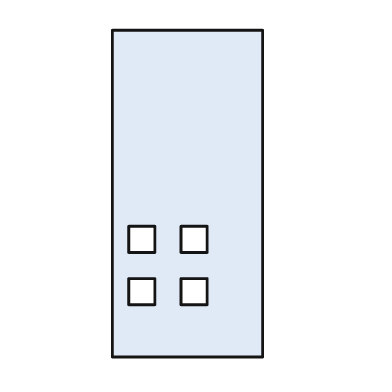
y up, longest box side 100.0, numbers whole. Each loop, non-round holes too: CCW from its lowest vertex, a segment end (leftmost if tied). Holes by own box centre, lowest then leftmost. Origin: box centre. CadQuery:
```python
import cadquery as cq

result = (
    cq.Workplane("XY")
    .moveTo(-23.0, -50.0)
    .lineTo(23.0, -50.0)
    .lineTo(23.0, 50.0)
    .lineTo(-23.0, 50.0)
    .close()
    .moveTo(-18.0, -34.0)
    .lineTo(-10.0, -34.0)
    .lineTo(-10.0, -26.0)
    .lineTo(-18.0, -26.0)
    .close()
    .moveTo(-2.0, -34.0)
    .lineTo(6.0, -34.0)
    .lineTo(6.0, -26.0)
    .lineTo(-2.0, -26.0)
    .close()
    .moveTo(-18.0, -18.0)
    .lineTo(-10.0, -18.0)
    .lineTo(-10.0, -10.0)
    .lineTo(-18.0, -10.0)
    .close()
    .moveTo(-2.0, -18.0)
    .lineTo(6.0, -18.0)
    .lineTo(6.0, -10.0)
    .lineTo(-2.0, -10.0)
    .close()
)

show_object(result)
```